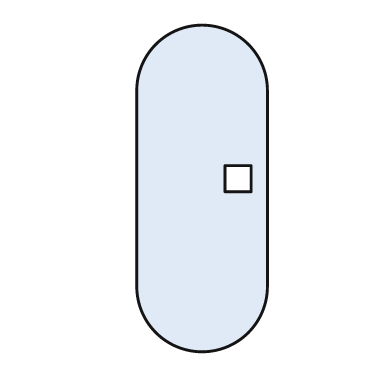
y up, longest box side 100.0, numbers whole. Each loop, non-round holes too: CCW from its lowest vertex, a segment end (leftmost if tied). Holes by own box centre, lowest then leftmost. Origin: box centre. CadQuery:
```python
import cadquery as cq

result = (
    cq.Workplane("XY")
    .moveTo(-20.0, -30.0)
    .threePointArc((0.0, -50.0), (20.0, -30.0))
    .lineTo(20.0, 30.0)
    .threePointArc((0.0, 50.0), (-20.0, 30.0))
    .close()
    .moveTo(7.0, -1.0)
    .lineTo(15.0, -1.0)
    .lineTo(15.0, 7.0)
    .lineTo(7.0, 7.0)
    .close()
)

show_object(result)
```